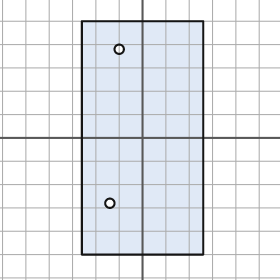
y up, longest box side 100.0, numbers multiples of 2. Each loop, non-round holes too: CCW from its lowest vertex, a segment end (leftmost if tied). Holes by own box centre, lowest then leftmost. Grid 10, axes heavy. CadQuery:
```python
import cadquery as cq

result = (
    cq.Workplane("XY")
    .moveTo(-26.0, -50.0)
    .lineTo(26.0, -50.0)
    .lineTo(26.0, 50.0)
    .lineTo(-26.0, 50.0)
    .close()
    .moveTo(-14.0, -28.0)
    .circle(2.0)
    .moveTo(-10.0, 38.0)
    .circle(2.0)
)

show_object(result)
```